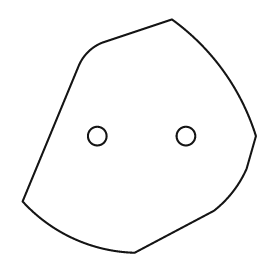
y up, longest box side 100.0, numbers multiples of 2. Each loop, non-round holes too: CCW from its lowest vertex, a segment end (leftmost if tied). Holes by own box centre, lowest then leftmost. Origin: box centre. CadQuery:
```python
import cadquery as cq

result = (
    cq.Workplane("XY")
    .moveTo(-2.0, -50.0)
    .lineTo(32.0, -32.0)
    .threePointArc((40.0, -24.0), (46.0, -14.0))
    .lineTo(50.0, 0.0)
    .threePointArc((36.0, 28.0), (14.0, 50.0))
    .lineTo(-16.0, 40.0)
    .threePointArc((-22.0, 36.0), (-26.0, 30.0))
    .lineTo(-50.0, -28.0)
    .threePointArc((-28.0, -44.0), (-2.0, -50.0))
    .close()
    .moveTo(-18.0, 0.0)
    .circle(4.0)
    .moveTo(20.0, 0.0)
    .circle(4.0)
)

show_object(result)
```